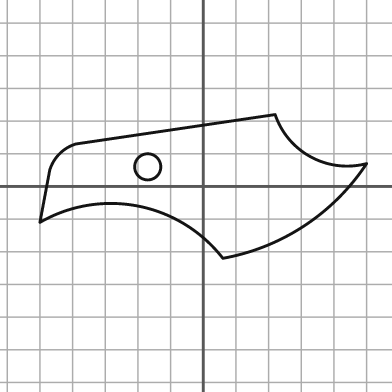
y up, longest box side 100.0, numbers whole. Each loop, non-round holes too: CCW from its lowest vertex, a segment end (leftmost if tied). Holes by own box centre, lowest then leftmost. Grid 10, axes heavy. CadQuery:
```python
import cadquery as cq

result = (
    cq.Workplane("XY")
    .moveTo(6.0, -22.0)
    .threePointArc((31.0, -12.0), (50.0, 7.0))
    .threePointArc((33.0, 9.0), (22.0, 22.0))
    .lineTo(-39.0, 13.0)
    .threePointArc((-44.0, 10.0), (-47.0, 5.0))
    .lineTo(-50.0, -11.0)
    .threePointArc((-20.0, -6.0), (6.0, -22.0))
    .close()
    .moveTo(-17.0, 6.0)
    .circle(4.0)
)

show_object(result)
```